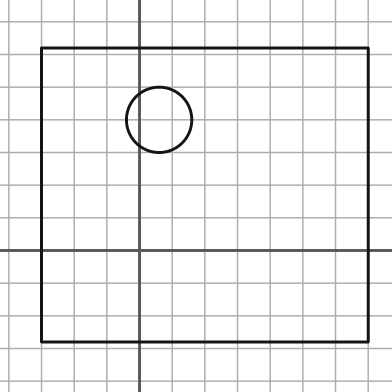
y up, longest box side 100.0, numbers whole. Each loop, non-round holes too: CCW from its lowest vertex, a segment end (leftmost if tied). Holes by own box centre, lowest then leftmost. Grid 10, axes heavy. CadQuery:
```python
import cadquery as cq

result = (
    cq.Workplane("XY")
    .moveTo(-30.0, -28.0)
    .lineTo(70.0, -28.0)
    .lineTo(70.0, 62.0)
    .lineTo(-30.0, 62.0)
    .close()
    .moveTo(6.0, 40.0)
    .circle(10.0)
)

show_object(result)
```